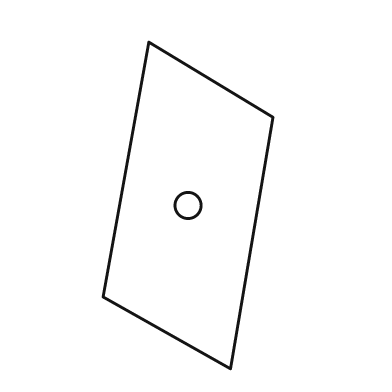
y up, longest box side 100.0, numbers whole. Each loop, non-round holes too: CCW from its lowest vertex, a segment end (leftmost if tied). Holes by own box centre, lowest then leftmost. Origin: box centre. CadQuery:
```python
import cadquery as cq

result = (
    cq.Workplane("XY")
    .moveTo(13.0, -50.0)
    .lineTo(26.0, 27.0)
    .lineTo(-12.0, 50.0)
    .lineTo(-26.0, -28.0)
    .close()
    .moveTo(0.0, 0.0)
    .circle(4.0)
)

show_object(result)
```